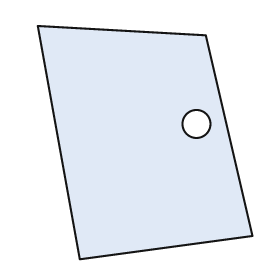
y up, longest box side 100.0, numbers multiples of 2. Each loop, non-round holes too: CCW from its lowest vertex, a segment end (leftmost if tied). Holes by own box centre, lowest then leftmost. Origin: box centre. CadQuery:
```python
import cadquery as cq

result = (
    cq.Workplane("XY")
    .moveTo(-28.0, -50.0)
    .lineTo(46.0, -40.0)
    .lineTo(26.0, 46.0)
    .lineTo(-46.0, 50.0)
    .close()
    .moveTo(22.0, 8.0)
    .circle(6.0)
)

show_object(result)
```